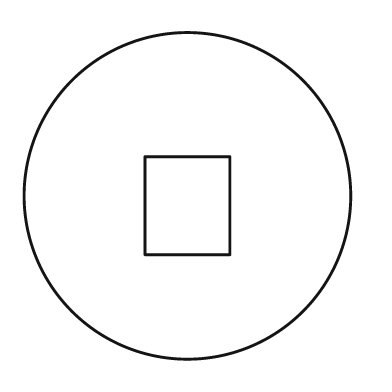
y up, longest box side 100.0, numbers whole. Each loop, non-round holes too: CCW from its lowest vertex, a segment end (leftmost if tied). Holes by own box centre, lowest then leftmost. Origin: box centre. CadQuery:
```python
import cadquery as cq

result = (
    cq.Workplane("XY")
    .moveTo(0.0, 0.0)
    .circle(50.0)
    .moveTo(-13.0, -18.0)
    .lineTo(13.0, -18.0)
    .lineTo(13.0, 12.0)
    .lineTo(-13.0, 12.0)
    .close()
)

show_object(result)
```